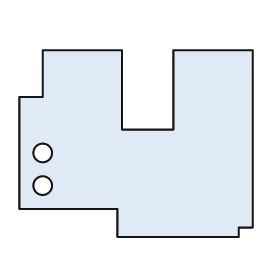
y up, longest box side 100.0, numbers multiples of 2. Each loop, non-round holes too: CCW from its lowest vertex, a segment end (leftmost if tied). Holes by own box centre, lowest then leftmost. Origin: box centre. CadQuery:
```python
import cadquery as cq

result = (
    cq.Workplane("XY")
    .moveTo(-8.0, -40.0)
    .lineTo(44.0, -40.0)
    .lineTo(44.0, -36.0)
    .lineTo(50.0, -36.0)
    .lineTo(50.0, 40.0)
    .lineTo(16.0, 40.0)
    .lineTo(16.0, 6.0)
    .lineTo(-6.0, 6.0)
    .lineTo(-6.0, 40.0)
    .lineTo(-40.0, 40.0)
    .lineTo(-40.0, 20.0)
    .lineTo(-50.0, 20.0)
    .lineTo(-50.0, -28.0)
    .lineTo(-8.0, -28.0)
    .close()
    .moveTo(-40.0, -18.0)
    .circle(4.0)
    .moveTo(-40.0, -4.0)
    .circle(4.0)
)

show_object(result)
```